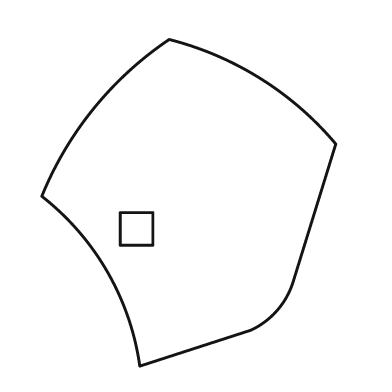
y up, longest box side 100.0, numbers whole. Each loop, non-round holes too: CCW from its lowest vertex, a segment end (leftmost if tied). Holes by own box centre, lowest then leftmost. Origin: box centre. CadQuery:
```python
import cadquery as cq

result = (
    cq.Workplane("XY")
    .moveTo(-15.0, -50.0)
    .lineTo(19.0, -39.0)
    .threePointArc((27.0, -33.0), (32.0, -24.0))
    .lineTo(45.0, 18.0)
    .threePointArc((22.0, 38.0), (-6.0, 50.0))
    .threePointArc((-29.0, 29.0), (-45.0, 2.0))
    .threePointArc((-25.0, -21.0), (-15.0, -50.0))
    .close()
    .moveTo(-21.0, -13.0)
    .lineTo(-11.0, -13.0)
    .lineTo(-11.0, -3.0)
    .lineTo(-21.0, -3.0)
    .close()
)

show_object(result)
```